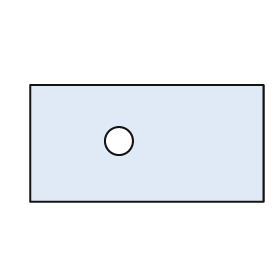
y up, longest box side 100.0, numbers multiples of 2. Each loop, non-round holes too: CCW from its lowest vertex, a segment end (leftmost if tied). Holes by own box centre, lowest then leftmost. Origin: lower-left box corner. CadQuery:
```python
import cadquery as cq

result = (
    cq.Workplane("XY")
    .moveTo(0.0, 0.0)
    .lineTo(100.0, 0.0)
    .lineTo(100.0, 50.0)
    .lineTo(0.0, 50.0)
    .close()
    .moveTo(38.0, 26.0)
    .circle(6.0)
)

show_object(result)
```